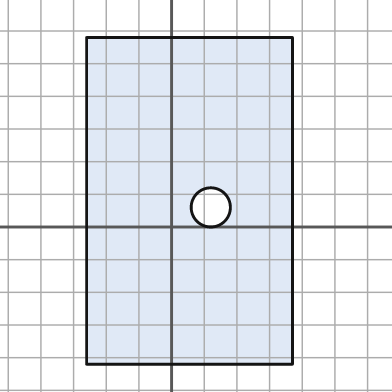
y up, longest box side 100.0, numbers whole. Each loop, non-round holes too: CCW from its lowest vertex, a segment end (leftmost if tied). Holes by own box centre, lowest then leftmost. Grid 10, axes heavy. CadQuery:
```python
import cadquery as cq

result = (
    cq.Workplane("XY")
    .moveTo(-26.0, -42.0)
    .lineTo(37.0, -42.0)
    .lineTo(37.0, 58.0)
    .lineTo(-26.0, 58.0)
    .close()
    .moveTo(12.0, 6.0)
    .circle(6.0)
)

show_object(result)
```